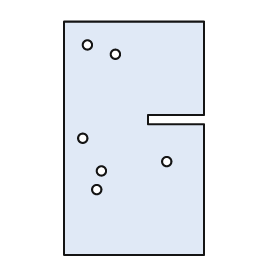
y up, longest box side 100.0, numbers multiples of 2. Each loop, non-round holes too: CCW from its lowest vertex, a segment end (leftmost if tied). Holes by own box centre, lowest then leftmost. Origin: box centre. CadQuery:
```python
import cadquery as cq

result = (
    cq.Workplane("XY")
    .moveTo(-30.0, -50.0)
    .lineTo(30.0, -50.0)
    .lineTo(30.0, 6.0)
    .lineTo(6.0, 6.0)
    .lineTo(6.0, 10.0)
    .lineTo(30.0, 10.0)
    .lineTo(30.0, 50.0)
    .lineTo(-30.0, 50.0)
    .close()
    .moveTo(-16.0, -22.0)
    .circle(2.0)
    .moveTo(-14.0, -14.0)
    .circle(2.0)
    .moveTo(14.0, -10.0)
    .circle(2.0)
    .moveTo(-22.0, 0.0)
    .circle(2.0)
    .moveTo(-8.0, 36.0)
    .circle(2.0)
    .moveTo(-20.0, 40.0)
    .circle(2.0)
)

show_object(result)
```